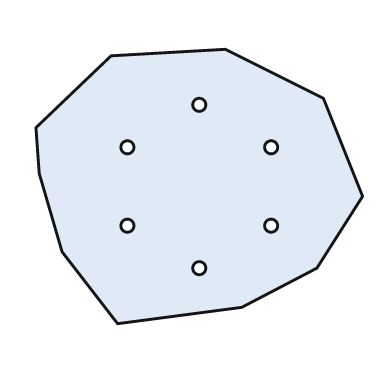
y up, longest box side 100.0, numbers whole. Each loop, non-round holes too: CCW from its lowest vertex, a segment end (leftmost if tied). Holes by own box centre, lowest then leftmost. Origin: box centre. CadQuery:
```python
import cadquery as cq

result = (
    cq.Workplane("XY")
    .moveTo(-25.0, -42.0)
    .lineTo(13.0, -37.0)
    .lineTo(36.0, -25.0)
    .lineTo(50.0, -3.0)
    .lineTo(38.0, 27.0)
    .lineTo(8.0, 42.0)
    .lineTo(-27.0, 40.0)
    .lineTo(-50.0, 18.0)
    .lineTo(-49.0, 4.0)
    .lineTo(-42.0, -20.0)
    .close()
    .moveTo(0.0, -25.0)
    .circle(2.0)
    .moveTo(-22.0, -12.0)
    .circle(2.0)
    .moveTo(22.0, -12.0)
    .circle(2.0)
    .moveTo(-22.0, 12.0)
    .circle(2.0)
    .moveTo(22.0, 12.0)
    .circle(2.0)
    .moveTo(0.0, 25.0)
    .circle(2.0)
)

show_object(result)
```